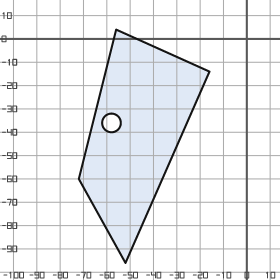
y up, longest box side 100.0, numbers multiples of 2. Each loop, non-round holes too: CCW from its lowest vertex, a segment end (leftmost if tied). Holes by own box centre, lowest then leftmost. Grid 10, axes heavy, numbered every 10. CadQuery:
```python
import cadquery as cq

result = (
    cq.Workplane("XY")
    .moveTo(-52.0, -96.0)
    .lineTo(-16.0, -14.0)
    .lineTo(-56.0, 4.0)
    .lineTo(-72.0, -60.0)
    .close()
    .moveTo(-58.0, -36.0)
    .circle(4.0)
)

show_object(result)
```